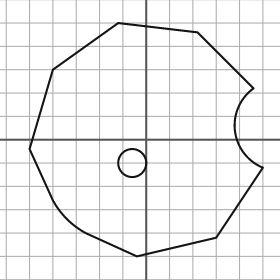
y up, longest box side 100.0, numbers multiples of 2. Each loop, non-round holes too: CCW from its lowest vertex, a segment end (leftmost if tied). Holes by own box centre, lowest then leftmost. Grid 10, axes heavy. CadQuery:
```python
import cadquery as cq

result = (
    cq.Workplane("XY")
    .moveTo(-4.0, -50.0)
    .lineTo(30.0, -42.0)
    .lineTo(50.0, -12.0)
    .threePointArc((38.0, 4.0), (46.0, 22.0))
    .lineTo(22.0, 46.0)
    .lineTo(-12.0, 50.0)
    .lineTo(-40.0, 30.0)
    .lineTo(-50.0, -4.0)
    .lineTo(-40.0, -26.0)
    .threePointArc((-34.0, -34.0), (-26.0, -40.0))
    .close()
    .moveTo(-6.0, -10.0)
    .circle(6.0)
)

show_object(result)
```